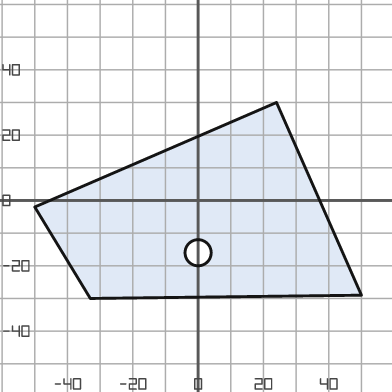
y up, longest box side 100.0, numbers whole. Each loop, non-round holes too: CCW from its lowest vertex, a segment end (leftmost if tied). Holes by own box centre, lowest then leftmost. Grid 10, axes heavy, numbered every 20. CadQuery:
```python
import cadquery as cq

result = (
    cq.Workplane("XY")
    .moveTo(-33.0, -30.0)
    .lineTo(50.0, -29.0)
    .lineTo(24.0, 30.0)
    .lineTo(-50.0, -2.0)
    .close()
    .moveTo(0.0, -16.0)
    .circle(4.0)
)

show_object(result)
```